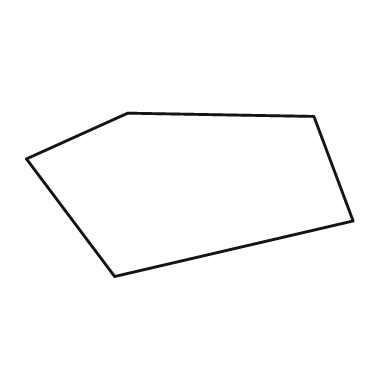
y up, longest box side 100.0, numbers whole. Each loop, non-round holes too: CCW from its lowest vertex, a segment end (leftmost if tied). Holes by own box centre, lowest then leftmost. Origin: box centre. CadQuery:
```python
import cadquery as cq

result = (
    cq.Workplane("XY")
    .moveTo(-23.0, -25.0)
    .lineTo(50.0, -8.0)
    .lineTo(38.0, 24.0)
    .lineTo(-19.0, 25.0)
    .lineTo(-50.0, 11.0)
    .close()
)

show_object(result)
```